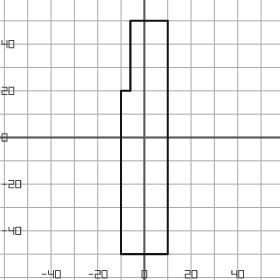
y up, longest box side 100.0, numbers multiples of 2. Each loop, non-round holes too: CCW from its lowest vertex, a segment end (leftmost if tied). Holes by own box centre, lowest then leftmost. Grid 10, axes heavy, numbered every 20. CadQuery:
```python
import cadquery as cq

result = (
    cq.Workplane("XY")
    .moveTo(-10.0, -50.0)
    .lineTo(10.0, -50.0)
    .lineTo(10.0, 50.0)
    .lineTo(-6.0, 50.0)
    .lineTo(-6.0, 20.0)
    .lineTo(-10.0, 20.0)
    .close()
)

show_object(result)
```